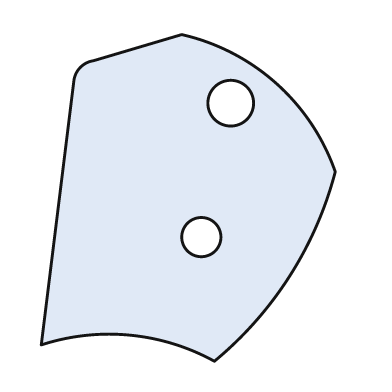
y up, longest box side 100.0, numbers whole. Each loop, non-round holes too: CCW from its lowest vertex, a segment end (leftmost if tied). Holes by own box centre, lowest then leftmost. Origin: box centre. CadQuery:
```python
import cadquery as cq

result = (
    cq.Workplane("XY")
    .moveTo(8.0, -50.0)
    .threePointArc((31.0, -24.0), (45.0, 8.0))
    .threePointArc((27.0, 35.0), (-2.0, 50.0))
    .lineTo(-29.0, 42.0)
    .threePointArc((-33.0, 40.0), (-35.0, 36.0))
    .lineTo(-45.0, -45.0)
    .threePointArc((-18.0, -42.0), (8.0, -50.0))
    .close()
    .moveTo(4.0, -12.0)
    .circle(6.0)
    .moveTo(13.0, 29.0)
    .circle(7.0)
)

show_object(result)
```